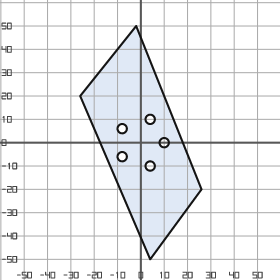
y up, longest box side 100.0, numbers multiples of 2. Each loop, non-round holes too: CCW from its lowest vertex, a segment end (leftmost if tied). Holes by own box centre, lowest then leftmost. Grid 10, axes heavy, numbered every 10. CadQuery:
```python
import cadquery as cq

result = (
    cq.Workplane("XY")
    .moveTo(4.0, -50.0)
    .lineTo(26.0, -20.0)
    .lineTo(-2.0, 50.0)
    .lineTo(-26.0, 20.0)
    .close()
    .moveTo(4.0, -10.0)
    .circle(2.0)
    .moveTo(-8.0, -6.0)
    .circle(2.0)
    .moveTo(10.0, 0.0)
    .circle(2.0)
    .moveTo(-8.0, 6.0)
    .circle(2.0)
    .moveTo(4.0, 10.0)
    .circle(2.0)
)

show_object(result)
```